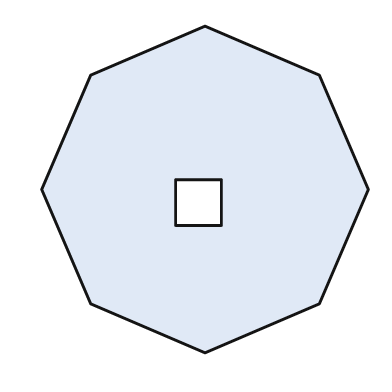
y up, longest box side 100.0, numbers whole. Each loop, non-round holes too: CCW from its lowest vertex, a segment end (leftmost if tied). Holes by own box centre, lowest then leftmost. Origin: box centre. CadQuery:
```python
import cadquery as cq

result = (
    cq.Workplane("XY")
    .moveTo(0.0, -50.0)
    .lineTo(35.0, -35.0)
    .lineTo(50.0, 0.0)
    .lineTo(35.0, 35.0)
    .lineTo(0.0, 50.0)
    .lineTo(-35.0, 35.0)
    .lineTo(-50.0, 0.0)
    .lineTo(-35.0, -35.0)
    .close()
    .moveTo(-9.0, -11.0)
    .lineTo(5.0, -11.0)
    .lineTo(5.0, 3.0)
    .lineTo(-9.0, 3.0)
    .close()
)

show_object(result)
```